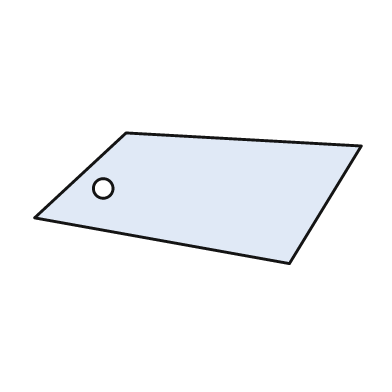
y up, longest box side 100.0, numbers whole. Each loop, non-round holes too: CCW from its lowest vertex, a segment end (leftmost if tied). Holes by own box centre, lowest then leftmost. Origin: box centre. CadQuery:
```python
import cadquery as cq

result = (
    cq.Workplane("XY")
    .moveTo(28.0, -20.0)
    .lineTo(50.0, 16.0)
    .lineTo(-22.0, 20.0)
    .lineTo(-50.0, -6.0)
    .close()
    .moveTo(-29.0, 3.0)
    .circle(3.0)
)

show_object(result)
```